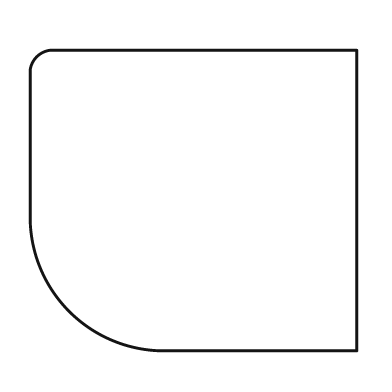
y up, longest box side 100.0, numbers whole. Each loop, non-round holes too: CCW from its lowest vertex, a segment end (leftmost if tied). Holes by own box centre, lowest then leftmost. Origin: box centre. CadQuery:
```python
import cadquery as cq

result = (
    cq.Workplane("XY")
    .moveTo(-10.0, -46.0)
    .lineTo(50.0, -46.0)
    .lineTo(50.0, 46.0)
    .lineTo(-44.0, 46.0)
    .threePointArc((-48.0, 44.0), (-50.0, 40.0))
    .lineTo(-50.0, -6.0)
    .threePointArc((-38.0, -34.0), (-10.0, -46.0))
    .close()
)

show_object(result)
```